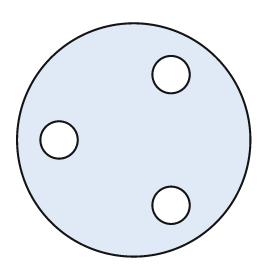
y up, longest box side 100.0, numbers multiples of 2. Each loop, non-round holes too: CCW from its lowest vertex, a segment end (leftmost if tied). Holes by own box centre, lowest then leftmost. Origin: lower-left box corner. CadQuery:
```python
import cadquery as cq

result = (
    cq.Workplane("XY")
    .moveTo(50.0, 50.0)
    .circle(50.0)
    .moveTo(66.0, 22.0)
    .circle(8.0)
    .moveTo(18.0, 50.0)
    .circle(8.0)
    .moveTo(66.0, 78.0)
    .circle(8.0)
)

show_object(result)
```